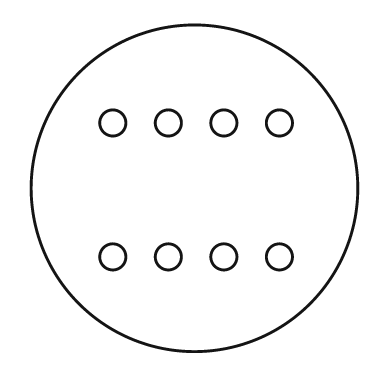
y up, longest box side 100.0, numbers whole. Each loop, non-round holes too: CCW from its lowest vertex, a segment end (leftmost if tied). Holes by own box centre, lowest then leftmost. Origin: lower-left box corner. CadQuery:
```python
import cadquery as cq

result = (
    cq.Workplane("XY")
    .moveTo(50.0, 50.0)
    .circle(50.0)
    .moveTo(25.0, 29.0)
    .circle(4.0)
    .moveTo(42.0, 29.0)
    .circle(4.0)
    .moveTo(59.0, 29.0)
    .circle(4.0)
    .moveTo(76.0, 29.0)
    .circle(4.0)
    .moveTo(25.0, 70.0)
    .circle(4.0)
    .moveTo(42.0, 70.0)
    .circle(4.0)
    .moveTo(59.0, 70.0)
    .circle(4.0)
    .moveTo(76.0, 70.0)
    .circle(4.0)
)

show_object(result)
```